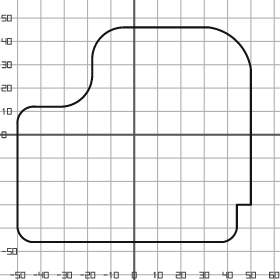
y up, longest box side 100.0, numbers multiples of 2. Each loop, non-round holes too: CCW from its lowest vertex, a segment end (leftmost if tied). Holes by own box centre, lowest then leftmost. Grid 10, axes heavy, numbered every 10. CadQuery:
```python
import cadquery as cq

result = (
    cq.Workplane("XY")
    .moveTo(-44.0, -46.0)
    .lineTo(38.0, -46.0)
    .threePointArc((42.0, -44.0), (44.0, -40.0))
    .lineTo(44.0, -30.0)
    .lineTo(50.0, -30.0)
    .lineTo(50.0, 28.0)
    .threePointArc((44.0, 40.0), (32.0, 46.0))
    .lineTo(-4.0, 46.0)
    .threePointArc((-14.0, 42.0), (-18.0, 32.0))
    .lineTo(-18.0, 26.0)
    .threePointArc((-22.0, 16.0), (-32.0, 12.0))
    .lineTo(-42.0, 12.0)
    .threePointArc((-48.0, 10.0), (-50.0, 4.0))
    .lineTo(-50.0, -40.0)
    .threePointArc((-48.0, -44.0), (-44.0, -46.0))
    .close()
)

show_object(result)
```